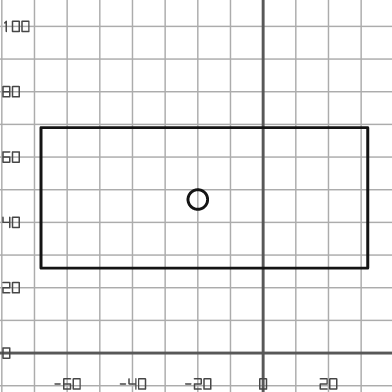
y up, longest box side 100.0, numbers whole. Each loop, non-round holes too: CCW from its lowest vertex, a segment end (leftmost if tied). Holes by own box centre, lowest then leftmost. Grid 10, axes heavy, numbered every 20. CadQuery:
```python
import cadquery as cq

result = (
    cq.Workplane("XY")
    .moveTo(-68.0, 26.0)
    .lineTo(32.0, 26.0)
    .lineTo(32.0, 69.0)
    .lineTo(-68.0, 69.0)
    .close()
    .moveTo(-20.0, 47.0)
    .circle(3.0)
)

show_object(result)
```